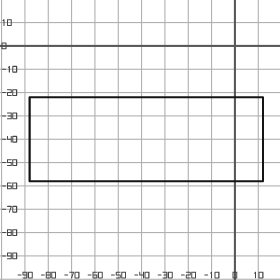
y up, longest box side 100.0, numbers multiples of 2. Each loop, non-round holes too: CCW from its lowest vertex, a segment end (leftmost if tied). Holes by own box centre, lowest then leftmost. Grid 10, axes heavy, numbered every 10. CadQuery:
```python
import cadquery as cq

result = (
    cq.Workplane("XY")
    .moveTo(-88.0, -58.0)
    .lineTo(12.0, -58.0)
    .lineTo(12.0, -22.0)
    .lineTo(-88.0, -22.0)
    .close()
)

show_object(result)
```